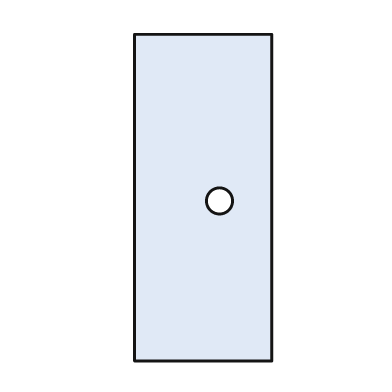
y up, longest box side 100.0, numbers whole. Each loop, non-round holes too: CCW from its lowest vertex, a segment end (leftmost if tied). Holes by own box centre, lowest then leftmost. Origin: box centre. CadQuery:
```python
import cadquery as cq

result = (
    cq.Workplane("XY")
    .moveTo(-21.0, -50.0)
    .lineTo(21.0, -50.0)
    .lineTo(21.0, 50.0)
    .lineTo(-21.0, 50.0)
    .close()
    .moveTo(5.0, -1.0)
    .circle(4.0)
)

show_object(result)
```